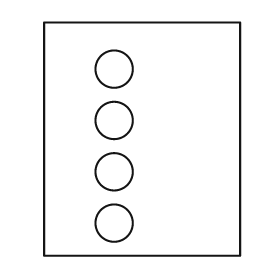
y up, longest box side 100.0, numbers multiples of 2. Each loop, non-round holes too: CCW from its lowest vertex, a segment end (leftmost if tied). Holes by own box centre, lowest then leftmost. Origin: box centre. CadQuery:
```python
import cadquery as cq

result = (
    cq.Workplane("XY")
    .moveTo(-42.0, -50.0)
    .lineTo(42.0, -50.0)
    .lineTo(42.0, 50.0)
    .lineTo(-42.0, 50.0)
    .close()
    .moveTo(-12.0, -36.0)
    .circle(8.0)
    .moveTo(-12.0, -14.0)
    .circle(8.0)
    .moveTo(-12.0, 8.0)
    .circle(8.0)
    .moveTo(-12.0, 30.0)
    .circle(8.0)
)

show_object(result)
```